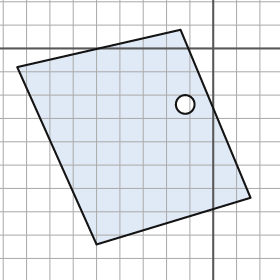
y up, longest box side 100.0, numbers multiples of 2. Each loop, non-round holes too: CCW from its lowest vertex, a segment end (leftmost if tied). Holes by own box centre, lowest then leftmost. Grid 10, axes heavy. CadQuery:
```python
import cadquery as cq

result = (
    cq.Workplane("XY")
    .moveTo(-50.0, -84.0)
    .lineTo(16.0, -64.0)
    .lineTo(-14.0, 8.0)
    .lineTo(-84.0, -8.0)
    .close()
    .moveTo(-12.0, -24.0)
    .circle(4.0)
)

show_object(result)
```